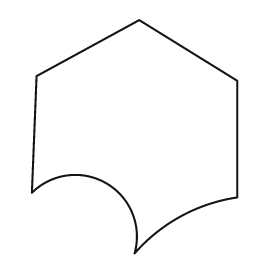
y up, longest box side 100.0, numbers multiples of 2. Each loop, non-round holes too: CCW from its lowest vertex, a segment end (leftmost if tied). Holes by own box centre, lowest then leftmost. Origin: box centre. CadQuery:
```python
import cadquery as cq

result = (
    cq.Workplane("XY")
    .moveTo(0.0, -50.0)
    .threePointArc((20.0, -34.0), (44.0, -26.0))
    .lineTo(44.0, 24.0)
    .lineTo(2.0, 50.0)
    .lineTo(-42.0, 26.0)
    .lineTo(-44.0, -24.0)
    .threePointArc((-12.0, -20.0), (0.0, -50.0))
    .close()
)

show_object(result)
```